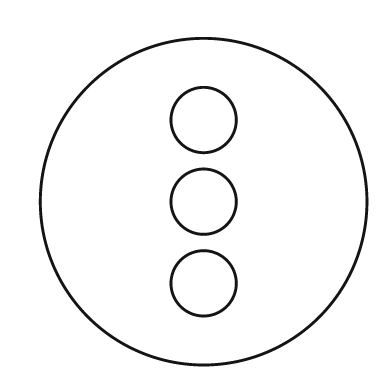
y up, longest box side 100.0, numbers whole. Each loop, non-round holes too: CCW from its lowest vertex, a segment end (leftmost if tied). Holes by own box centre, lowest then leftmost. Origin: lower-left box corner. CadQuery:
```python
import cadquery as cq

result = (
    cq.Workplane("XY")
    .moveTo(50.0, 50.0)
    .circle(50.0)
    .moveTo(50.0, 25.0)
    .circle(10.0)
    .moveTo(50.0, 50.0)
    .circle(10.0)
    .moveTo(50.0, 75.0)
    .circle(10.0)
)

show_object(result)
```